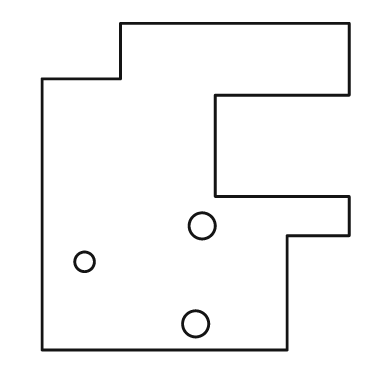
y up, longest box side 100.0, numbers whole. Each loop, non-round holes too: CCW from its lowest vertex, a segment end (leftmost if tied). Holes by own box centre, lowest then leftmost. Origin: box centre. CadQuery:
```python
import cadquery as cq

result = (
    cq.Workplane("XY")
    .moveTo(-47.0, -50.0)
    .lineTo(28.0, -50.0)
    .lineTo(28.0, -15.0)
    .lineTo(47.0, -15.0)
    .lineTo(47.0, -3.0)
    .lineTo(6.0, -3.0)
    .lineTo(6.0, 28.0)
    .lineTo(47.0, 28.0)
    .lineTo(47.0, 50.0)
    .lineTo(-23.0, 50.0)
    .lineTo(-23.0, 33.0)
    .lineTo(-47.0, 33.0)
    .close()
    .moveTo(0.0, -42.0)
    .circle(4.0)
    .moveTo(-34.0, -23.0)
    .circle(3.0)
    .moveTo(2.0, -12.0)
    .circle(4.0)
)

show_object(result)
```